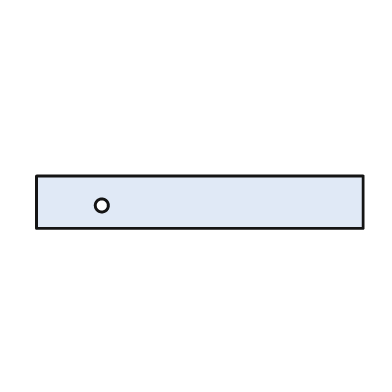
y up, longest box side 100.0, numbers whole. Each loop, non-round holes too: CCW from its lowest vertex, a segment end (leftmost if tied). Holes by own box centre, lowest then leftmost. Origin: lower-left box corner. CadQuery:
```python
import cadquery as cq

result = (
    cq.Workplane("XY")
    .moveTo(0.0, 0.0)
    .lineTo(100.0, 0.0)
    .lineTo(100.0, 16.0)
    .lineTo(0.0, 16.0)
    .close()
    .moveTo(20.0, 7.0)
    .circle(2.0)
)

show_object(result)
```